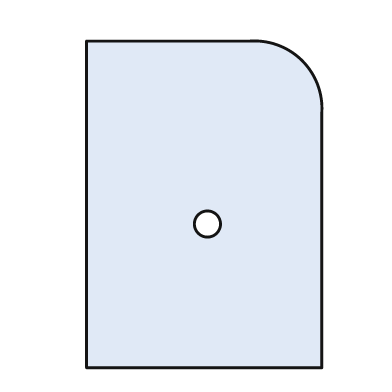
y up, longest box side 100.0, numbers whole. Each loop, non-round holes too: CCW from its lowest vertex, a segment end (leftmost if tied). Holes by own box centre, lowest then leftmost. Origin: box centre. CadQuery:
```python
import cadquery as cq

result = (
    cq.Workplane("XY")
    .moveTo(-36.0, -50.0)
    .lineTo(36.0, -50.0)
    .lineTo(36.0, 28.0)
    .threePointArc((30.0, 44.0), (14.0, 50.0))
    .lineTo(-36.0, 50.0)
    .close()
    .moveTo(1.0, -6.0)
    .circle(4.0)
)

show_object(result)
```